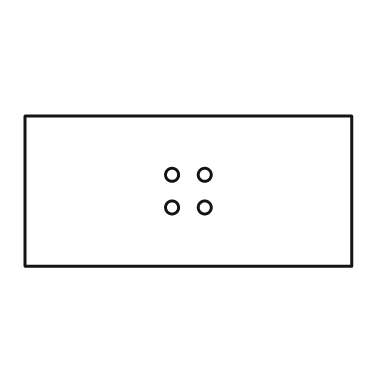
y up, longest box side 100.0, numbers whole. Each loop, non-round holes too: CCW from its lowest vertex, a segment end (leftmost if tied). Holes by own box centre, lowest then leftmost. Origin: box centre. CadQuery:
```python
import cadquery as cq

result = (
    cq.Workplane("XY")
    .moveTo(-50.0, -23.0)
    .lineTo(50.0, -23.0)
    .lineTo(50.0, 23.0)
    .lineTo(-50.0, 23.0)
    .close()
    .moveTo(-5.0, -5.0)
    .circle(2.0)
    .moveTo(5.0, -5.0)
    .circle(2.0)
    .moveTo(-5.0, 5.0)
    .circle(2.0)
    .moveTo(5.0, 5.0)
    .circle(2.0)
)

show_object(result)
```